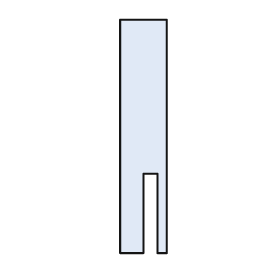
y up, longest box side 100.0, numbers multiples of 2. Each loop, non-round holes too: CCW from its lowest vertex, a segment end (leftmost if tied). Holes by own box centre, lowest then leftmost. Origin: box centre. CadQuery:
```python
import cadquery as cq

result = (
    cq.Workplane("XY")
    .moveTo(-10.0, -50.0)
    .lineTo(0.0, -50.0)
    .lineTo(0.0, -16.0)
    .lineTo(6.0, -16.0)
    .lineTo(6.0, -50.0)
    .lineTo(10.0, -50.0)
    .lineTo(10.0, 50.0)
    .lineTo(-10.0, 50.0)
    .close()
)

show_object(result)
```